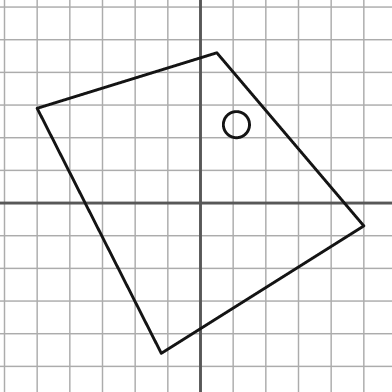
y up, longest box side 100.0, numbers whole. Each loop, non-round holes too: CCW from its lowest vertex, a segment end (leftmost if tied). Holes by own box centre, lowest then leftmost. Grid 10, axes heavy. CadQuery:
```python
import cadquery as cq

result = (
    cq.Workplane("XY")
    .moveTo(-12.0, -46.0)
    .lineTo(50.0, -7.0)
    .lineTo(5.0, 46.0)
    .lineTo(-50.0, 29.0)
    .close()
    .moveTo(11.0, 24.0)
    .circle(4.0)
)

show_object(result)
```